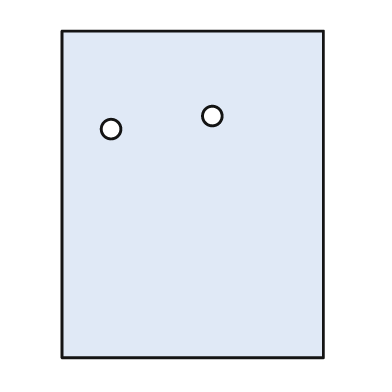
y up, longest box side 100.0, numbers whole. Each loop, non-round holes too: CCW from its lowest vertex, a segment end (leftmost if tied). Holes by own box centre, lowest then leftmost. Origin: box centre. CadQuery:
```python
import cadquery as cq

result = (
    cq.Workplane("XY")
    .moveTo(-40.0, -50.0)
    .lineTo(40.0, -50.0)
    .lineTo(40.0, 50.0)
    .lineTo(-40.0, 50.0)
    .close()
    .moveTo(-25.0, 20.0)
    .circle(3.0)
    .moveTo(6.0, 24.0)
    .circle(3.0)
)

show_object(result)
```